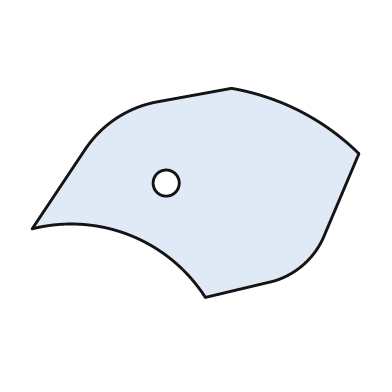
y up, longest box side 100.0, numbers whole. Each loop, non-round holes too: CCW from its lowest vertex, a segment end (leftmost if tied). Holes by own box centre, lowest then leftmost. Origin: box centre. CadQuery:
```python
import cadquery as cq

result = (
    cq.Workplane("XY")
    .moveTo(3.0, -32.0)
    .lineTo(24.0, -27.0)
    .threePointArc((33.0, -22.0), (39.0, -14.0))
    .lineTo(50.0, 12.0)
    .threePointArc((32.0, 25.0), (11.0, 32.0))
    .lineTo(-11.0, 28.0)
    .threePointArc((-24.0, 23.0), (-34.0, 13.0))
    .lineTo(-50.0, -11.0)
    .threePointArc((-20.0, -13.0), (3.0, -32.0))
    .close()
    .moveTo(-9.0, 3.0)
    .circle(4.0)
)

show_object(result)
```